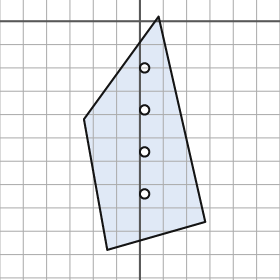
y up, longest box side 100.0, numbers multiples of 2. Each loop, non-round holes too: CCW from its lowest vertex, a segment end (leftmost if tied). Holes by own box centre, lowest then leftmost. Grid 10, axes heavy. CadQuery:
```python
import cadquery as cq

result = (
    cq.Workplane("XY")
    .moveTo(-14.0, -98.0)
    .lineTo(28.0, -86.0)
    .lineTo(8.0, 2.0)
    .lineTo(-24.0, -42.0)
    .close()
    .moveTo(2.0, -74.0)
    .circle(2.0)
    .moveTo(2.0, -56.0)
    .circle(2.0)
    .moveTo(2.0, -38.0)
    .circle(2.0)
    .moveTo(2.0, -20.0)
    .circle(2.0)
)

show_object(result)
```